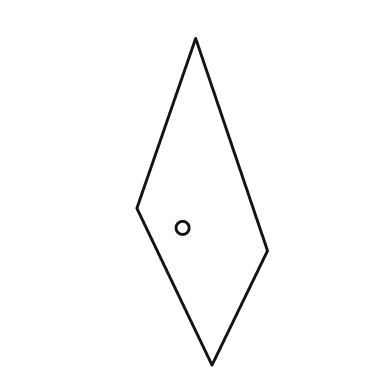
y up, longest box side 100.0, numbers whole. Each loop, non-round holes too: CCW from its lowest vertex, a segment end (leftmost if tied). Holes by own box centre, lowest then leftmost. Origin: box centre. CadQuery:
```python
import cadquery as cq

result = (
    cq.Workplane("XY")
    .moveTo(3.0, -50.0)
    .lineTo(20.0, -15.0)
    .lineTo(-2.0, 50.0)
    .lineTo(-20.0, -2.0)
    .close()
    .moveTo(-6.0, -8.0)
    .circle(2.0)
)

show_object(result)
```